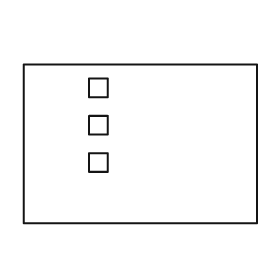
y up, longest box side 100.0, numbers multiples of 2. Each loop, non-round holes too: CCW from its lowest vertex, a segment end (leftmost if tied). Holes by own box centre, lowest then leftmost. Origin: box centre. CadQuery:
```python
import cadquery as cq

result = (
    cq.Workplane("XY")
    .moveTo(-50.0, -34.0)
    .lineTo(50.0, -34.0)
    .lineTo(50.0, 34.0)
    .lineTo(-50.0, 34.0)
    .close()
    .moveTo(-22.0, -12.0)
    .lineTo(-14.0, -12.0)
    .lineTo(-14.0, -4.0)
    .lineTo(-22.0, -4.0)
    .close()
    .moveTo(-22.0, 4.0)
    .lineTo(-14.0, 4.0)
    .lineTo(-14.0, 12.0)
    .lineTo(-22.0, 12.0)
    .close()
    .moveTo(-22.0, 20.0)
    .lineTo(-14.0, 20.0)
    .lineTo(-14.0, 28.0)
    .lineTo(-22.0, 28.0)
    .close()
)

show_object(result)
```